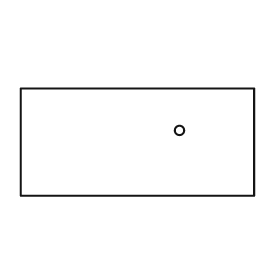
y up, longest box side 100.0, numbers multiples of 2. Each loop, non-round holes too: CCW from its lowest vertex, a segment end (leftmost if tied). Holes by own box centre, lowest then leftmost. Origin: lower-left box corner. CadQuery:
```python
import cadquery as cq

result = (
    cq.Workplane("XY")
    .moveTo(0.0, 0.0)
    .lineTo(100.0, 0.0)
    .lineTo(100.0, 46.0)
    .lineTo(0.0, 46.0)
    .close()
    .moveTo(68.0, 28.0)
    .circle(2.0)
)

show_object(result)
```